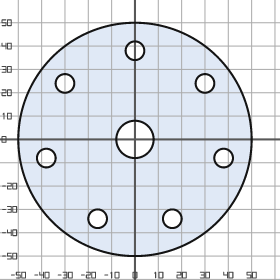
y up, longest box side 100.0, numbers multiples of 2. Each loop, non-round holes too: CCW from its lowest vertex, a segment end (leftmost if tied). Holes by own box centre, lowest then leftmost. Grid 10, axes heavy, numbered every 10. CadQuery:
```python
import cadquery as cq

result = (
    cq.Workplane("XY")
    .moveTo(0.0, 0.0)
    .circle(50.0)
    .moveTo(-16.0, -34.0)
    .circle(4.0)
    .moveTo(16.0, -34.0)
    .circle(4.0)
    .moveTo(-38.0, -8.0)
    .circle(4.0)
    .moveTo(38.0, -8.0)
    .circle(4.0)
    .moveTo(0.0, 0.0)
    .circle(8.0)
    .moveTo(-30.0, 24.0)
    .circle(4.0)
    .moveTo(30.0, 24.0)
    .circle(4.0)
    .moveTo(0.0, 38.0)
    .circle(4.0)
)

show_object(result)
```